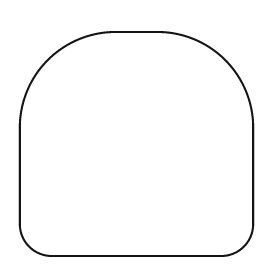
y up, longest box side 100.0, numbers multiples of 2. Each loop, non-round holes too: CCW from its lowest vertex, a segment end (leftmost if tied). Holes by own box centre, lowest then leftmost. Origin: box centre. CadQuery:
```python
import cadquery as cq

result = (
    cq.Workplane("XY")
    .moveTo(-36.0, -48.0)
    .lineTo(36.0, -48.0)
    .threePointArc((46.0, -44.0), (50.0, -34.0))
    .lineTo(50.0, 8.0)
    .threePointArc((38.0, 36.0), (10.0, 48.0))
    .lineTo(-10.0, 48.0)
    .threePointArc((-38.0, 36.0), (-50.0, 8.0))
    .lineTo(-50.0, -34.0)
    .threePointArc((-46.0, -44.0), (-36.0, -48.0))
    .close()
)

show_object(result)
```